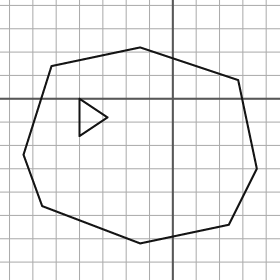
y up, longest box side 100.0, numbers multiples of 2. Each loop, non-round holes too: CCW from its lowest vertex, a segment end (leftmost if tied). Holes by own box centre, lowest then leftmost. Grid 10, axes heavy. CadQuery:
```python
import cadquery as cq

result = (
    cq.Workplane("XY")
    .moveTo(-14.0, -62.0)
    .lineTo(24.0, -54.0)
    .lineTo(36.0, -30.0)
    .lineTo(28.0, 8.0)
    .lineTo(-14.0, 22.0)
    .lineTo(-52.0, 14.0)
    .lineTo(-64.0, -24.0)
    .lineTo(-56.0, -46.0)
    .close()
    .moveTo(-40.0, -16.0)
    .lineTo(-28.0, -8.0)
    .lineTo(-40.0, 0.0)
    .close()
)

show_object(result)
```